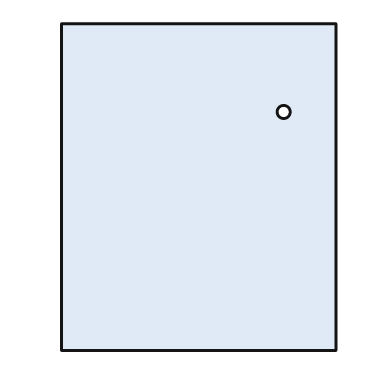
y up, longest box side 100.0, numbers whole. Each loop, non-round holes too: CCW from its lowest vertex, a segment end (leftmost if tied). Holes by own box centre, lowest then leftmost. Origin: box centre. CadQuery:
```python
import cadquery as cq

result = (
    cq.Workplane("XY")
    .moveTo(-42.0, -50.0)
    .lineTo(42.0, -50.0)
    .lineTo(42.0, 50.0)
    .lineTo(-42.0, 50.0)
    .close()
    .moveTo(26.0, 23.0)
    .circle(2.0)
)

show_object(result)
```